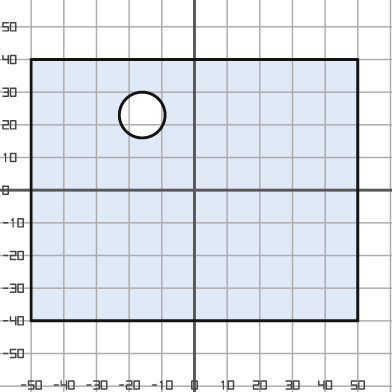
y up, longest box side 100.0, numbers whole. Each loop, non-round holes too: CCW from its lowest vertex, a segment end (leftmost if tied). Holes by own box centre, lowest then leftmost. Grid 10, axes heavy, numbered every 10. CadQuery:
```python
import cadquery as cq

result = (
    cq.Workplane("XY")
    .moveTo(-50.0, -40.0)
    .lineTo(50.0, -40.0)
    .lineTo(50.0, 40.0)
    .lineTo(-50.0, 40.0)
    .close()
    .moveTo(-16.0, 23.0)
    .circle(7.0)
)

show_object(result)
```